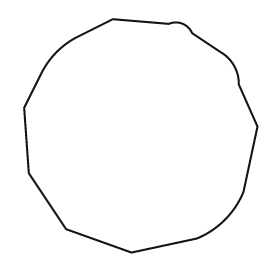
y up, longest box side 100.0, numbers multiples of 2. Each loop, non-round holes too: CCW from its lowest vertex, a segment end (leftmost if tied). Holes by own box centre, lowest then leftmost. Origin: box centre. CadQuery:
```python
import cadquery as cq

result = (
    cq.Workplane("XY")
    .moveTo(-4.0, -50.0)
    .lineTo(24.0, -44.0)
    .threePointArc((36.0, -36.0), (44.0, -24.0))
    .lineTo(50.0, 4.0)
    .lineTo(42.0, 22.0)
    .threePointArc((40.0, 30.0), (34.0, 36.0))
    .lineTo(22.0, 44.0)
    .threePointArc((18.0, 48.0), (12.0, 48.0))
    .lineTo(-12.0, 50.0)
    .lineTo(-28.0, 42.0)
    .threePointArc((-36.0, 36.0), (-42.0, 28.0))
    .lineTo(-50.0, 12.0)
    .lineTo(-48.0, -16.0)
    .lineTo(-32.0, -40.0)
    .close()
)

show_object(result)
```